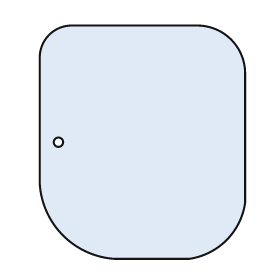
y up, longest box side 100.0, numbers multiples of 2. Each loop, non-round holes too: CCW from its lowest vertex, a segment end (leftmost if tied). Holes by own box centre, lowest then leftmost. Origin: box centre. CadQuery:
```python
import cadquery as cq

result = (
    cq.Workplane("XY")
    .moveTo(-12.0, -50.0)
    .lineTo(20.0, -50.0)
    .threePointArc((36.0, -42.0), (44.0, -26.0))
    .lineTo(44.0, 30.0)
    .threePointArc((38.0, 44.0), (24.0, 50.0))
    .lineTo(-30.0, 50.0)
    .threePointArc((-40.0, 46.0), (-44.0, 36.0))
    .lineTo(-44.0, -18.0)
    .threePointArc((-34.0, -40.0), (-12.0, -50.0))
    .close()
    .moveTo(-36.0, 0.0)
    .circle(2.0)
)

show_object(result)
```